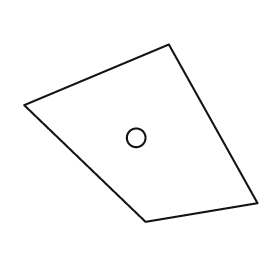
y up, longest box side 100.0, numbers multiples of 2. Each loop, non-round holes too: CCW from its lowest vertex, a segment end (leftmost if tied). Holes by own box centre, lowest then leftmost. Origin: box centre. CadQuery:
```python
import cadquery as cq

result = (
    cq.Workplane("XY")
    .moveTo(2.0, -38.0)
    .lineTo(50.0, -30.0)
    .lineTo(12.0, 38.0)
    .lineTo(-50.0, 12.0)
    .close()
    .moveTo(-2.0, -2.0)
    .circle(4.0)
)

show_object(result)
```